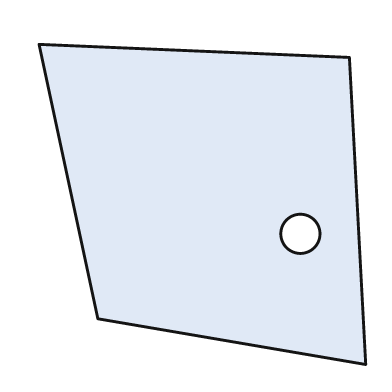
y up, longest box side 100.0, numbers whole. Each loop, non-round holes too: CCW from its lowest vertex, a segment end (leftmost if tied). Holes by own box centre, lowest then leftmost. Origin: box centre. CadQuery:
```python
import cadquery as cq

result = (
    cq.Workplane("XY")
    .moveTo(50.0, -49.0)
    .lineTo(45.0, 45.0)
    .lineTo(-50.0, 49.0)
    .lineTo(-32.0, -35.0)
    .close()
    .moveTo(30.0, -9.0)
    .circle(6.0)
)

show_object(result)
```